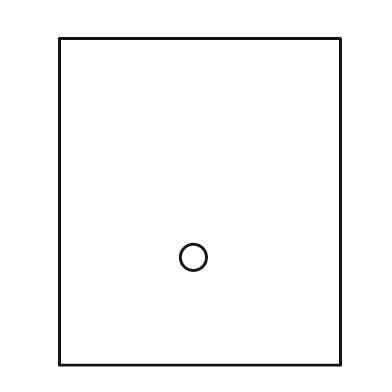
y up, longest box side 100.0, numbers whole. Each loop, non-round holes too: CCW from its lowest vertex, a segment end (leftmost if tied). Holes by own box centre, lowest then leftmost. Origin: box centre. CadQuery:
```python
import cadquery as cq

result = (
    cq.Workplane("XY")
    .moveTo(-43.0, -50.0)
    .lineTo(43.0, -50.0)
    .lineTo(43.0, 50.0)
    .lineTo(-43.0, 50.0)
    .close()
    .moveTo(-2.0, -17.0)
    .circle(4.0)
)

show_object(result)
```